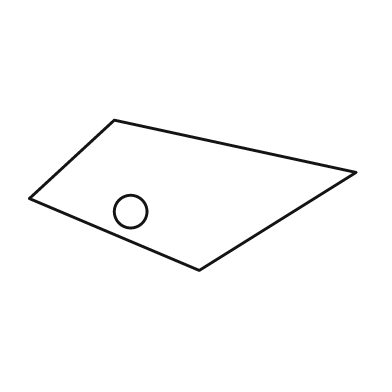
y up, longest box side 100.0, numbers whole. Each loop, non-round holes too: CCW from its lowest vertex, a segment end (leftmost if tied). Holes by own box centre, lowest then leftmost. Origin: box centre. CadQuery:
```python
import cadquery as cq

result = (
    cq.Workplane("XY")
    .moveTo(2.0, -23.0)
    .lineTo(50.0, 7.0)
    .lineTo(-24.0, 23.0)
    .lineTo(-50.0, -1.0)
    .close()
    .moveTo(-19.0, -5.0)
    .circle(5.0)
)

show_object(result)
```